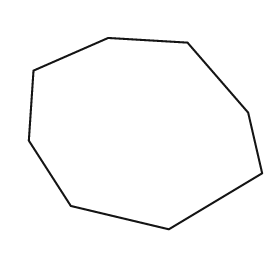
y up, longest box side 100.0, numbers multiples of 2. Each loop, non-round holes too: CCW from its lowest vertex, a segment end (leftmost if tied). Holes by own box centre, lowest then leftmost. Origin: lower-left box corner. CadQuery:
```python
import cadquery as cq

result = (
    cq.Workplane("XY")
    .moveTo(60.0, 0.0)
    .lineTo(100.0, 24.0)
    .lineTo(94.0, 50.0)
    .lineTo(68.0, 80.0)
    .lineTo(34.0, 82.0)
    .lineTo(2.0, 68.0)
    .lineTo(0.0, 38.0)
    .lineTo(18.0, 10.0)
    .close()
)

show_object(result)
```